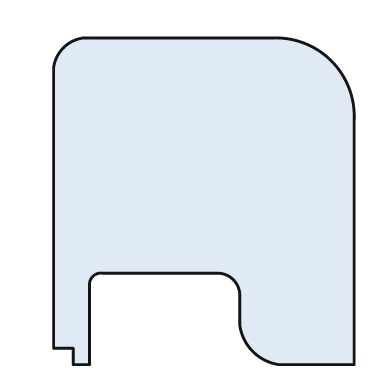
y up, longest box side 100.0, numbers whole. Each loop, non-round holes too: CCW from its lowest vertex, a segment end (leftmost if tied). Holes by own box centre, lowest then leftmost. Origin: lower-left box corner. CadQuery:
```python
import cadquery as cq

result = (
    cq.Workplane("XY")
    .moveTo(6.0, 0.0)
    .lineTo(11.0, 0.0)
    .lineTo(11.0, 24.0)
    .threePointArc((12.0, 27.0), (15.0, 28.0))
    .lineTo(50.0, 28.0)
    .threePointArc((55.0, 26.0), (57.0, 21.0))
    .lineTo(57.0, 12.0)
    .threePointArc((61.0, 4.0), (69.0, 0.0))
    .lineTo(92.0, 0.0)
    .lineTo(92.0, 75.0)
    .threePointArc((85.0, 93.0), (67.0, 100.0))
    .lineTo(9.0, 100.0)
    .threePointArc((3.0, 97.0), (0.0, 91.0))
    .lineTo(0.0, 5.0)
    .lineTo(6.0, 5.0)
    .close()
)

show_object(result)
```